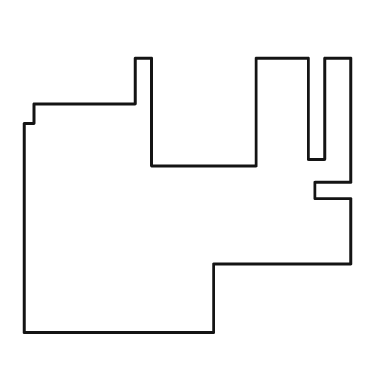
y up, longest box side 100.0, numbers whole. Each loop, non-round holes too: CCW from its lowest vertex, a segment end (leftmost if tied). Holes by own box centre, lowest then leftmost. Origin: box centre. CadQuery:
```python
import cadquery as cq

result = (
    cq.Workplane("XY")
    .moveTo(-50.0, -42.0)
    .lineTo(8.0, -42.0)
    .lineTo(8.0, -21.0)
    .lineTo(50.0, -21.0)
    .lineTo(50.0, -1.0)
    .lineTo(39.0, -1.0)
    .lineTo(39.0, 4.0)
    .lineTo(50.0, 4.0)
    .lineTo(50.0, 42.0)
    .lineTo(42.0, 42.0)
    .lineTo(42.0, 11.0)
    .lineTo(37.0, 11.0)
    .lineTo(37.0, 42.0)
    .lineTo(21.0, 42.0)
    .lineTo(21.0, 9.0)
    .lineTo(-11.0, 9.0)
    .lineTo(-11.0, 42.0)
    .lineTo(-16.0, 42.0)
    .lineTo(-16.0, 28.0)
    .lineTo(-47.0, 28.0)
    .lineTo(-47.0, 22.0)
    .lineTo(-50.0, 22.0)
    .close()
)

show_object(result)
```